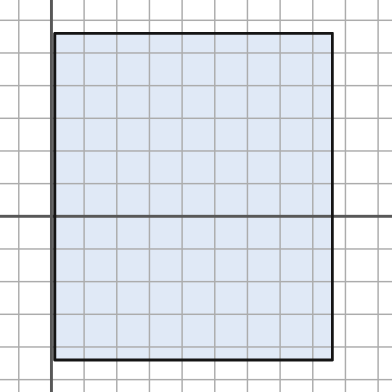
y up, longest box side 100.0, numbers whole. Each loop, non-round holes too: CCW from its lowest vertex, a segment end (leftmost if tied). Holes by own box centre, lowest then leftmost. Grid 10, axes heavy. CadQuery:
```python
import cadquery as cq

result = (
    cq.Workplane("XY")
    .moveTo(1.0, -44.0)
    .lineTo(86.0, -44.0)
    .lineTo(86.0, 56.0)
    .lineTo(1.0, 56.0)
    .close()
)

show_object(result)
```